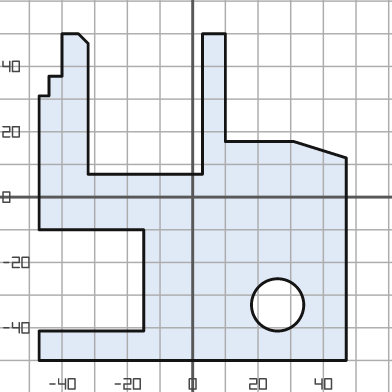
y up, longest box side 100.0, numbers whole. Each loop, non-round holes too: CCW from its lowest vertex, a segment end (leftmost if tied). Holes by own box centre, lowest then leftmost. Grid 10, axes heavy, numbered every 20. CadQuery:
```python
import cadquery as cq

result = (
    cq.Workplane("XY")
    .moveTo(-47.0, -50.0)
    .lineTo(47.0, -50.0)
    .lineTo(47.0, 12.0)
    .lineTo(31.0, 17.0)
    .lineTo(10.0, 17.0)
    .lineTo(10.0, 50.0)
    .lineTo(3.0, 50.0)
    .lineTo(3.0, 7.0)
    .lineTo(-32.0, 7.0)
    .lineTo(-32.0, 47.0)
    .lineTo(-35.0, 50.0)
    .lineTo(-40.0, 50.0)
    .lineTo(-40.0, 37.0)
    .lineTo(-44.0, 37.0)
    .lineTo(-44.0, 31.0)
    .lineTo(-47.0, 31.0)
    .lineTo(-47.0, -10.0)
    .lineTo(-15.0, -10.0)
    .lineTo(-15.0, -41.0)
    .lineTo(-47.0, -41.0)
    .close()
    .moveTo(26.0, -33.0)
    .circle(8.0)
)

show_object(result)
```